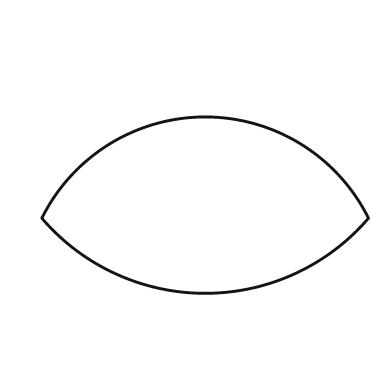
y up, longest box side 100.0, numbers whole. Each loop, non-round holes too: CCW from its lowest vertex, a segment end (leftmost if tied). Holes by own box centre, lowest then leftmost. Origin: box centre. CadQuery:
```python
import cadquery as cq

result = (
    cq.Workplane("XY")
    .moveTo(-50.0, -4.0)
    .threePointArc((0.0, -27.0), (50.0, -4.0))
    .threePointArc((0.0, 27.0), (-50.0, -4.0))
    .close()
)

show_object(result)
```